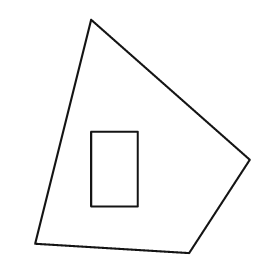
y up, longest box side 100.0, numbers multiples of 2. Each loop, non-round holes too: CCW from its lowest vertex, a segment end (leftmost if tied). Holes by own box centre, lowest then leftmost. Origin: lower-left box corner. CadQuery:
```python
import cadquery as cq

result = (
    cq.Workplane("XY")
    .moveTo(66.0, 0.0)
    .lineTo(92.0, 40.0)
    .lineTo(24.0, 100.0)
    .lineTo(0.0, 4.0)
    .close()
    .moveTo(24.0, 20.0)
    .lineTo(44.0, 20.0)
    .lineTo(44.0, 52.0)
    .lineTo(24.0, 52.0)
    .close()
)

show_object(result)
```